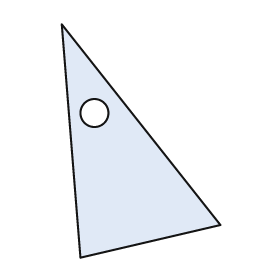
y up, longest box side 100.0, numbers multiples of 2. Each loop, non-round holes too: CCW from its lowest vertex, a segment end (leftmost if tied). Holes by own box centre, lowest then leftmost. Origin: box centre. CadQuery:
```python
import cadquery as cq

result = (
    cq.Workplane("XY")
    .moveTo(-26.0, -50.0)
    .lineTo(34.0, -36.0)
    .lineTo(-34.0, 50.0)
    .close()
    .moveTo(-20.0, 12.0)
    .circle(6.0)
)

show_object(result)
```